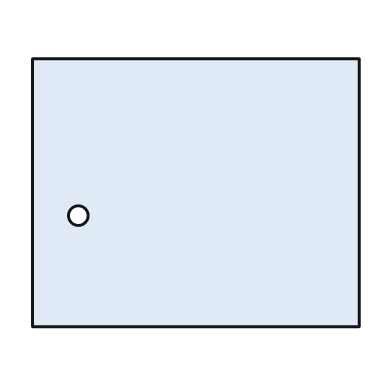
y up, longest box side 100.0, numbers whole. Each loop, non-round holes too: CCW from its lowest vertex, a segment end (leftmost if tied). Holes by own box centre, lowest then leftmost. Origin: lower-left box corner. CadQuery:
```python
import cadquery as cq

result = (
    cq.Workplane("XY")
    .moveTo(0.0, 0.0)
    .lineTo(100.0, 0.0)
    .lineTo(100.0, 82.0)
    .lineTo(0.0, 82.0)
    .close()
    .moveTo(14.0, 34.0)
    .circle(3.0)
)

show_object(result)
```